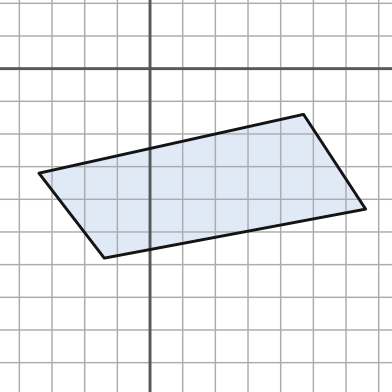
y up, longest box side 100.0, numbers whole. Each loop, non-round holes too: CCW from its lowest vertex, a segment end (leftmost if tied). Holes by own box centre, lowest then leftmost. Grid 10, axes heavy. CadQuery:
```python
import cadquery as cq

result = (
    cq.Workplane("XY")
    .moveTo(-14.0, -58.0)
    .lineTo(66.0, -43.0)
    .lineTo(47.0, -14.0)
    .lineTo(-34.0, -32.0)
    .close()
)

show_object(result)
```